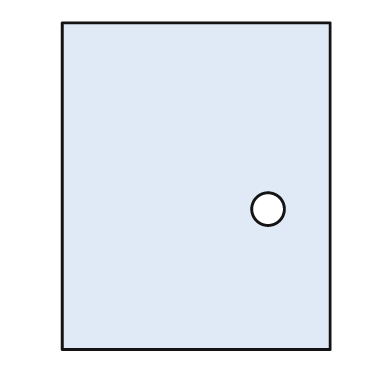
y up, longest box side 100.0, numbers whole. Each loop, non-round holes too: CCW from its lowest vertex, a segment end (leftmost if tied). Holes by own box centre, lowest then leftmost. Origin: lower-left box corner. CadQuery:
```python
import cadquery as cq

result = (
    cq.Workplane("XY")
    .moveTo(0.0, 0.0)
    .lineTo(82.0, 0.0)
    .lineTo(82.0, 100.0)
    .lineTo(0.0, 100.0)
    .close()
    .moveTo(63.0, 43.0)
    .circle(5.0)
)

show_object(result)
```